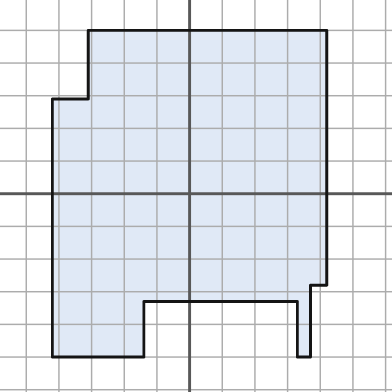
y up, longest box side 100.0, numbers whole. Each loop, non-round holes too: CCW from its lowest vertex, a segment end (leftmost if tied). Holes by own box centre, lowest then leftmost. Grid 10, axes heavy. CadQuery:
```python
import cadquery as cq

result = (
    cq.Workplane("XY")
    .moveTo(-42.0, -50.0)
    .lineTo(-14.0, -50.0)
    .lineTo(-14.0, -33.0)
    .lineTo(33.0, -33.0)
    .lineTo(33.0, -50.0)
    .lineTo(37.0, -50.0)
    .lineTo(37.0, -28.0)
    .lineTo(42.0, -28.0)
    .lineTo(42.0, 50.0)
    .lineTo(-31.0, 50.0)
    .lineTo(-31.0, 29.0)
    .lineTo(-42.0, 29.0)
    .close()
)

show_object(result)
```